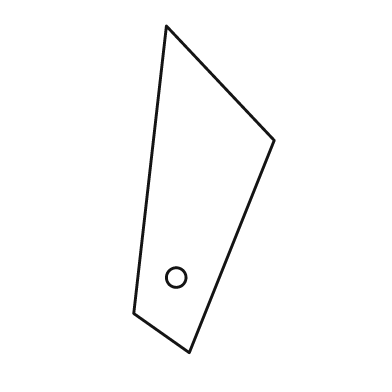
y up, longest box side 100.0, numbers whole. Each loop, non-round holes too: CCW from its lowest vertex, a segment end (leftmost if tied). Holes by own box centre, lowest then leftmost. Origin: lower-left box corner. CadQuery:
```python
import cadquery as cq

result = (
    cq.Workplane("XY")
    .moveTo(17.0, 0.0)
    .lineTo(43.0, 65.0)
    .lineTo(10.0, 100.0)
    .lineTo(0.0, 12.0)
    .close()
    .moveTo(13.0, 23.0)
    .circle(3.0)
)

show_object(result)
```